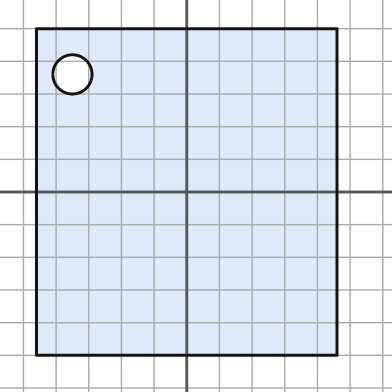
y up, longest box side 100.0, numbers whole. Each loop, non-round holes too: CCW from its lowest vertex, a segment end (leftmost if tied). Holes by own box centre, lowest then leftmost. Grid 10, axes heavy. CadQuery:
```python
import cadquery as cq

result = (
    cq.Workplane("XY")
    .moveTo(-46.0, -50.0)
    .lineTo(46.0, -50.0)
    .lineTo(46.0, 50.0)
    .lineTo(-46.0, 50.0)
    .close()
    .moveTo(-35.0, 36.0)
    .circle(6.0)
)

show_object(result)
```